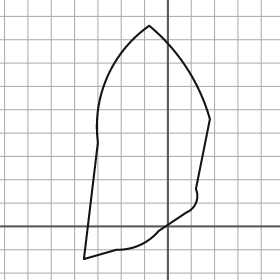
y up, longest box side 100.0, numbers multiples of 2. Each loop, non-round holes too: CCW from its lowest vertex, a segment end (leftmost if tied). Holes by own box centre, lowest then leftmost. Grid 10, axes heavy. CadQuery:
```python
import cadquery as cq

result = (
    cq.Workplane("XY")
    .moveTo(-36.0, -14.0)
    .lineTo(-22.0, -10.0)
    .threePointArc((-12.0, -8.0), (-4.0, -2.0))
    .lineTo(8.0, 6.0)
    .threePointArc((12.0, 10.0), (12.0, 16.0))
    .lineTo(18.0, 46.0)
    .threePointArc((8.0, 68.0), (-8.0, 86.0))
    .threePointArc((-26.0, 64.0), (-30.0, 36.0))
    .close()
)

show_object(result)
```